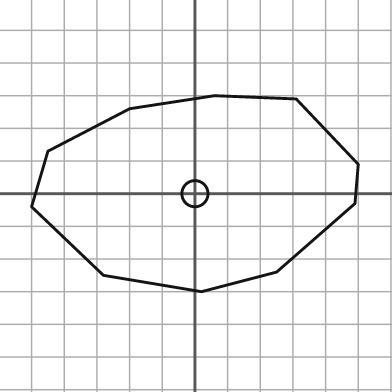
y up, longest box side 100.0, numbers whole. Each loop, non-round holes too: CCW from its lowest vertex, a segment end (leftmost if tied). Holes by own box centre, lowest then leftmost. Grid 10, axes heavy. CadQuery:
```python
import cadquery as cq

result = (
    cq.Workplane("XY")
    .moveTo(2.0, -30.0)
    .lineTo(25.0, -24.0)
    .lineTo(49.0, -3.0)
    .lineTo(50.0, 9.0)
    .lineTo(31.0, 29.0)
    .lineTo(6.0, 30.0)
    .lineTo(-20.0, 26.0)
    .lineTo(-45.0, 13.0)
    .lineTo(-50.0, -4.0)
    .lineTo(-28.0, -25.0)
    .close()
    .moveTo(0.0, 0.0)
    .circle(4.0)
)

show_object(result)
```